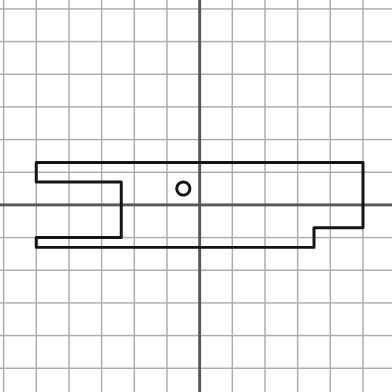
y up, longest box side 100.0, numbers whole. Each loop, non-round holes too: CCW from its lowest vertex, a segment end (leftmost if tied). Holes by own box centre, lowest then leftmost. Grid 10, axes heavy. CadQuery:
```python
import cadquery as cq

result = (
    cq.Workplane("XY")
    .moveTo(-50.0, -13.0)
    .lineTo(35.0, -13.0)
    .lineTo(35.0, -7.0)
    .lineTo(50.0, -7.0)
    .lineTo(50.0, 13.0)
    .lineTo(-50.0, 13.0)
    .lineTo(-50.0, 7.0)
    .lineTo(-24.0, 7.0)
    .lineTo(-24.0, -10.0)
    .lineTo(-50.0, -10.0)
    .close()
    .moveTo(-5.0, 5.0)
    .circle(2.0)
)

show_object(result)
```